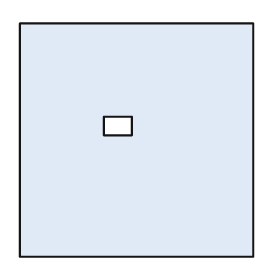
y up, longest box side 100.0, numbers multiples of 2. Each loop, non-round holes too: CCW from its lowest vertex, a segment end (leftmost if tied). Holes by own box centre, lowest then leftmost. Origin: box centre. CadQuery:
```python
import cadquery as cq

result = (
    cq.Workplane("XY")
    .moveTo(-50.0, -50.0)
    .lineTo(50.0, -50.0)
    .lineTo(50.0, 50.0)
    .lineTo(-50.0, 50.0)
    .close()
    .moveTo(-14.0, 2.0)
    .lineTo(-2.0, 2.0)
    .lineTo(-2.0, 10.0)
    .lineTo(-14.0, 10.0)
    .close()
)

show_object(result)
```